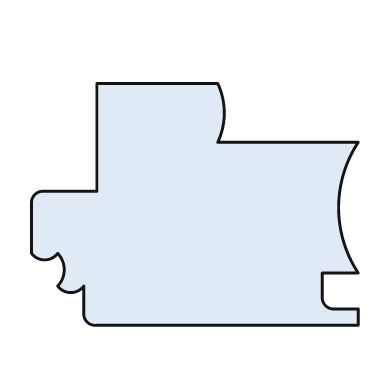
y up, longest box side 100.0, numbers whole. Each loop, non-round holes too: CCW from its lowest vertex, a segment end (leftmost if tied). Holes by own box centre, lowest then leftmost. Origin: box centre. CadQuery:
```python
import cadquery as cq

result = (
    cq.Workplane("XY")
    .moveTo(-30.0, -37.0)
    .lineTo(50.0, -37.0)
    .lineTo(50.0, -32.0)
    .lineTo(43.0, -32.0)
    .threePointArc((40.0, -31.0), (39.0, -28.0))
    .lineTo(39.0, -21.0)
    .lineTo(50.0, -21.0)
    .threePointArc((44.0, -1.0), (50.0, 19.0))
    .lineTo(7.0, 19.0)
    .threePointArc((9.0, 28.0), (7.0, 37.0))
    .lineTo(-30.0, 37.0)
    .lineTo(-30.0, 4.0)
    .lineTo(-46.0, 4.0)
    .threePointArc((-49.0, 3.0), (-50.0, 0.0))
    .lineTo(-50.0, -15.0)
    .threePointArc((-46.0, -17.0), (-42.0, -15.0))
    .threePointArc((-40.0, -20.0), (-42.0, -25.0))
    .threePointArc((-38.0, -27.0), (-34.0, -25.0))
    .lineTo(-34.0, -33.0)
    .threePointArc((-33.0, -36.0), (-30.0, -37.0))
    .close()
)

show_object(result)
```